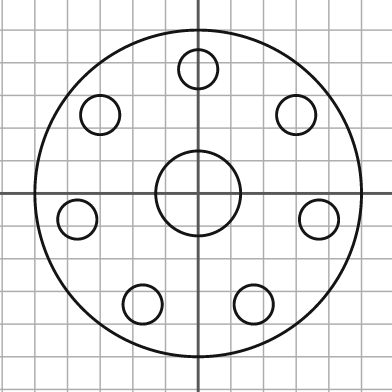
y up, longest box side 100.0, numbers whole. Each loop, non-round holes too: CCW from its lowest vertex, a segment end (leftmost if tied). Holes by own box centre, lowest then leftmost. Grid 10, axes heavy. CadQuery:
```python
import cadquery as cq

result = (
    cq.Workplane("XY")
    .moveTo(0.0, 0.0)
    .circle(50.0)
    .moveTo(-17.0, -34.0)
    .circle(6.0)
    .moveTo(17.0, -34.0)
    .circle(6.0)
    .moveTo(-37.0, -8.0)
    .circle(6.0)
    .moveTo(37.0, -8.0)
    .circle(6.0)
    .moveTo(0.0, 0.0)
    .circle(13.0)
    .moveTo(-30.0, 24.0)
    .circle(6.0)
    .moveTo(30.0, 24.0)
    .circle(6.0)
    .moveTo(0.0, 38.0)
    .circle(6.0)
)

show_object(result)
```